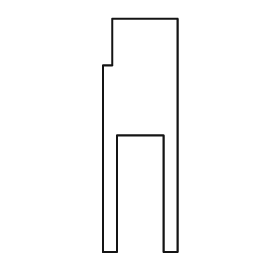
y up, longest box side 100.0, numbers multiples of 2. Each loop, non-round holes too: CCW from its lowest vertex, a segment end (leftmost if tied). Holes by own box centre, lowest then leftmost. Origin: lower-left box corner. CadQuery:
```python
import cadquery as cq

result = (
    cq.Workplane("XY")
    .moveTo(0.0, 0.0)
    .lineTo(6.0, 0.0)
    .lineTo(6.0, 50.0)
    .lineTo(26.0, 50.0)
    .lineTo(26.0, 0.0)
    .lineTo(32.0, 0.0)
    .lineTo(32.0, 100.0)
    .lineTo(4.0, 100.0)
    .lineTo(4.0, 80.0)
    .lineTo(0.0, 80.0)
    .close()
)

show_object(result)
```